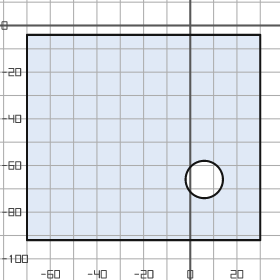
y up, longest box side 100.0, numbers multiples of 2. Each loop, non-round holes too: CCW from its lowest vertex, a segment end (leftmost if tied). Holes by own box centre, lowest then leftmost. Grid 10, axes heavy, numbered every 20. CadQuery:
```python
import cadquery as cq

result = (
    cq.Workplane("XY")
    .moveTo(-70.0, -92.0)
    .lineTo(30.0, -92.0)
    .lineTo(30.0, -4.0)
    .lineTo(-70.0, -4.0)
    .close()
    .moveTo(6.0, -66.0)
    .circle(8.0)
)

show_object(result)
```